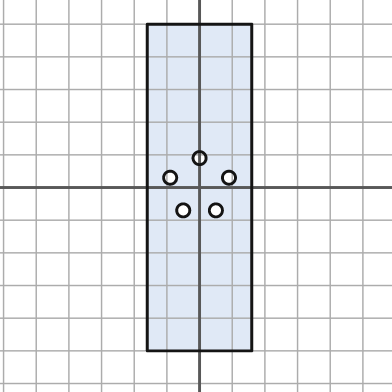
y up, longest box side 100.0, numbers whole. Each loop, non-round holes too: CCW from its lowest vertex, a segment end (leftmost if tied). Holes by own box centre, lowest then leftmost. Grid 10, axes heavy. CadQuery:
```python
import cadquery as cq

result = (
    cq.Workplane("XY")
    .moveTo(-16.0, -50.0)
    .lineTo(16.0, -50.0)
    .lineTo(16.0, 50.0)
    .lineTo(-16.0, 50.0)
    .close()
    .moveTo(-5.0, -7.0)
    .circle(2.0)
    .moveTo(5.0, -7.0)
    .circle(2.0)
    .moveTo(-9.0, 3.0)
    .circle(2.0)
    .moveTo(9.0, 3.0)
    .circle(2.0)
    .moveTo(0.0, 9.0)
    .circle(2.0)
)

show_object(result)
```